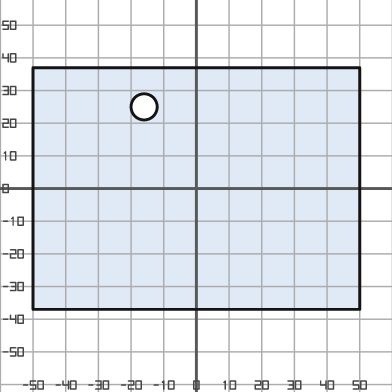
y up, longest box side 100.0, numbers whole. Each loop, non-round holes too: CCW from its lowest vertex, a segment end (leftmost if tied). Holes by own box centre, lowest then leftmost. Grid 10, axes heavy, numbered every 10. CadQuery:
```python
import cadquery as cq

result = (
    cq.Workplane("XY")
    .moveTo(-50.0, -37.0)
    .lineTo(50.0, -37.0)
    .lineTo(50.0, 37.0)
    .lineTo(-50.0, 37.0)
    .close()
    .moveTo(-16.0, 25.0)
    .circle(4.0)
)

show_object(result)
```